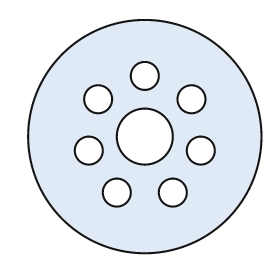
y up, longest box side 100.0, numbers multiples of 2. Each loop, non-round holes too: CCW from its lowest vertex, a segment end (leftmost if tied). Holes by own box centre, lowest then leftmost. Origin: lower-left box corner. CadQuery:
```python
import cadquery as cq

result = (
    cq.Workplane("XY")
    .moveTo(50.0, 50.0)
    .circle(50.0)
    .moveTo(38.0, 26.0)
    .circle(6.0)
    .moveTo(62.0, 26.0)
    .circle(6.0)
    .moveTo(26.0, 44.0)
    .circle(6.0)
    .moveTo(74.0, 44.0)
    .circle(6.0)
    .moveTo(50.0, 50.0)
    .circle(12.0)
    .moveTo(30.0, 66.0)
    .circle(6.0)
    .moveTo(70.0, 66.0)
    .circle(6.0)
    .moveTo(50.0, 76.0)
    .circle(6.0)
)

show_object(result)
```